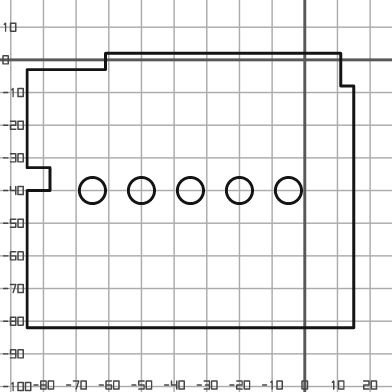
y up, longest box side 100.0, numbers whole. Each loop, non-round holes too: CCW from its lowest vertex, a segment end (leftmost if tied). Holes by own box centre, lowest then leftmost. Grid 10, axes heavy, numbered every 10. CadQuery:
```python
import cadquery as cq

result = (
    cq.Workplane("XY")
    .moveTo(-85.0, -82.0)
    .lineTo(15.0, -82.0)
    .lineTo(15.0, -8.0)
    .lineTo(11.0, -8.0)
    .lineTo(11.0, 2.0)
    .lineTo(-61.0, 2.0)
    .lineTo(-61.0, -3.0)
    .lineTo(-85.0, -3.0)
    .lineTo(-85.0, -33.0)
    .lineTo(-78.0, -33.0)
    .lineTo(-78.0, -40.0)
    .lineTo(-85.0, -40.0)
    .close()
    .moveTo(-65.0, -40.0)
    .circle(4.0)
    .moveTo(-50.0, -40.0)
    .circle(4.0)
    .moveTo(-35.0, -40.0)
    .circle(4.0)
    .moveTo(-20.0, -40.0)
    .circle(4.0)
    .moveTo(-5.0, -40.0)
    .circle(4.0)
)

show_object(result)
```